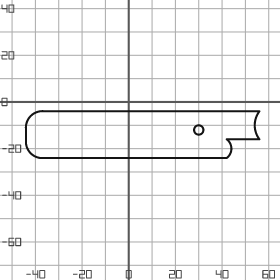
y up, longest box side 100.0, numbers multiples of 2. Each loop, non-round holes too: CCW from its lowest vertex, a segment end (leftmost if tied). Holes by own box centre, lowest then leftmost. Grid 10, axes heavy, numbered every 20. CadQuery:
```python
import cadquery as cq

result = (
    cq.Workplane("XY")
    .moveTo(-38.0, -24.0)
    .lineTo(42.0, -24.0)
    .threePointArc((44.0, -20.0), (42.0, -16.0))
    .lineTo(56.0, -16.0)
    .threePointArc((54.0, -10.0), (56.0, -4.0))
    .lineTo(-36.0, -4.0)
    .threePointArc((-42.0, -6.0), (-44.0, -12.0))
    .lineTo(-44.0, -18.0)
    .threePointArc((-42.0, -22.0), (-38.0, -24.0))
    .close()
    .moveTo(30.0, -12.0)
    .circle(2.0)
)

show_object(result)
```